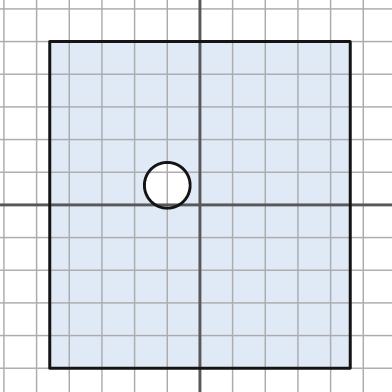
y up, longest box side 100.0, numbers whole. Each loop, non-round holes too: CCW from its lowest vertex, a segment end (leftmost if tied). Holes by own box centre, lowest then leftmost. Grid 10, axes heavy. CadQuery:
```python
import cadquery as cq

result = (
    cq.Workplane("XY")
    .moveTo(-46.0, -50.0)
    .lineTo(46.0, -50.0)
    .lineTo(46.0, 50.0)
    .lineTo(-46.0, 50.0)
    .close()
    .moveTo(-10.0, 6.0)
    .circle(7.0)
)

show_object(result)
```